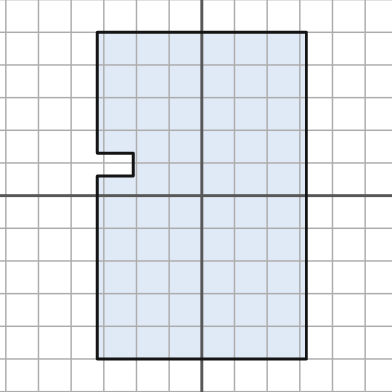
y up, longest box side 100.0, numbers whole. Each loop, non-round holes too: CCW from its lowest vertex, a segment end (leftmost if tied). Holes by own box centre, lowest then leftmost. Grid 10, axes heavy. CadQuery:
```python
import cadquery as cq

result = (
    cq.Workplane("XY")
    .moveTo(-32.0, -50.0)
    .lineTo(32.0, -50.0)
    .lineTo(32.0, 50.0)
    .lineTo(-32.0, 50.0)
    .lineTo(-32.0, 13.0)
    .lineTo(-21.0, 13.0)
    .lineTo(-21.0, 6.0)
    .lineTo(-32.0, 6.0)
    .close()
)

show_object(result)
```